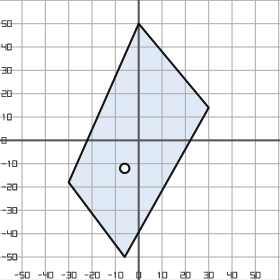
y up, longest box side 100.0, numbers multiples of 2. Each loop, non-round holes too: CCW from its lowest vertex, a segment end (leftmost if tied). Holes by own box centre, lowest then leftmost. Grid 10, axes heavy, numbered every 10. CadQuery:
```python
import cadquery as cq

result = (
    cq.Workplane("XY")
    .moveTo(-6.0, -50.0)
    .lineTo(30.0, 14.0)
    .lineTo(0.0, 50.0)
    .lineTo(-30.0, -18.0)
    .close()
    .moveTo(-6.0, -12.0)
    .circle(2.0)
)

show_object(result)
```